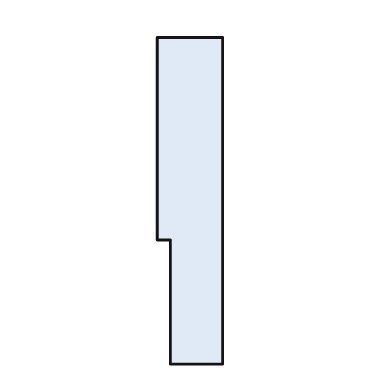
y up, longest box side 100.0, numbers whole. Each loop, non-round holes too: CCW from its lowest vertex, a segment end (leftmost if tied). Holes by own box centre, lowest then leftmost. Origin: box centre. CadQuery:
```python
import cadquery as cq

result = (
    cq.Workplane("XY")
    .moveTo(-6.0, -50.0)
    .lineTo(10.0, -50.0)
    .lineTo(10.0, 50.0)
    .lineTo(-10.0, 50.0)
    .lineTo(-10.0, -12.0)
    .lineTo(-6.0, -12.0)
    .close()
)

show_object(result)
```